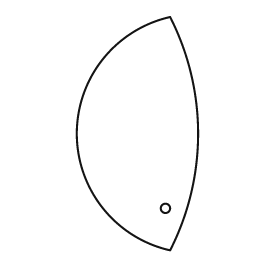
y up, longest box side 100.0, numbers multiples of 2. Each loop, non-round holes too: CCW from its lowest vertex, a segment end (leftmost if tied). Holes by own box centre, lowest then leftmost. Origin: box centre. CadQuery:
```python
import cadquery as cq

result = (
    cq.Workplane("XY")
    .moveTo(14.0, -50.0)
    .threePointArc((26.0, 0.0), (14.0, 50.0))
    .threePointArc((-26.0, 0.0), (14.0, -50.0))
    .close()
    .moveTo(12.0, -32.0)
    .circle(2.0)
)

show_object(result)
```